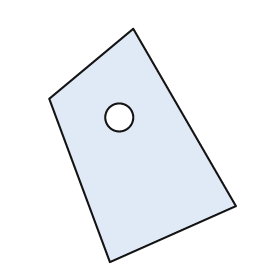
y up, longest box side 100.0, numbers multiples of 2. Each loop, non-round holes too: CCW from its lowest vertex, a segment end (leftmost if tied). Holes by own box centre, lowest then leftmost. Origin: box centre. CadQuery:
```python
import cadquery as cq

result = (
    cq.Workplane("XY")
    .moveTo(-14.0, -50.0)
    .lineTo(40.0, -26.0)
    .lineTo(-4.0, 50.0)
    .lineTo(-40.0, 20.0)
    .close()
    .moveTo(-10.0, 12.0)
    .circle(6.0)
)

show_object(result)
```